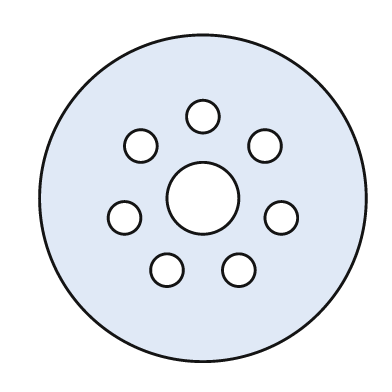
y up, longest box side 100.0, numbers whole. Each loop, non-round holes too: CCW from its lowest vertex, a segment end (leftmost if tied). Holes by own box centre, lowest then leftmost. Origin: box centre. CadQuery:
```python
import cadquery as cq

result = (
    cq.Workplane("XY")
    .moveTo(0.0, 0.0)
    .circle(50.0)
    .moveTo(-11.0, -22.0)
    .circle(5.0)
    .moveTo(11.0, -22.0)
    .circle(5.0)
    .moveTo(-24.0, -6.0)
    .circle(5.0)
    .moveTo(24.0, -6.0)
    .circle(5.0)
    .moveTo(0.0, 0.0)
    .circle(11.0)
    .moveTo(-19.0, 16.0)
    .circle(5.0)
    .moveTo(19.0, 16.0)
    .circle(5.0)
    .moveTo(0.0, 25.0)
    .circle(5.0)
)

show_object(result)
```